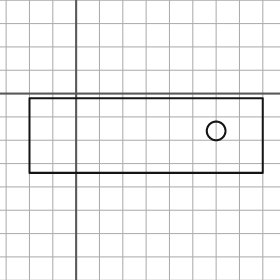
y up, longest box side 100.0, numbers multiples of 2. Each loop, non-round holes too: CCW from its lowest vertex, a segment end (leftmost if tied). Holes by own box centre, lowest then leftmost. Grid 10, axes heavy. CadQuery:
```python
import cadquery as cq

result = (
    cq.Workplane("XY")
    .moveTo(-20.0, -34.0)
    .lineTo(80.0, -34.0)
    .lineTo(80.0, -2.0)
    .lineTo(-20.0, -2.0)
    .close()
    .moveTo(60.0, -16.0)
    .circle(4.0)
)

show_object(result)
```